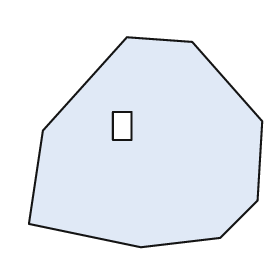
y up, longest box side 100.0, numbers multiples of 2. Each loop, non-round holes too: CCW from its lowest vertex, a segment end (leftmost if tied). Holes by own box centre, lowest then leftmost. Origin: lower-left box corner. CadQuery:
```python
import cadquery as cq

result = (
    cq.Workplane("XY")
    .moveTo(48.0, 0.0)
    .lineTo(82.0, 4.0)
    .lineTo(98.0, 20.0)
    .lineTo(100.0, 54.0)
    .lineTo(70.0, 88.0)
    .lineTo(42.0, 90.0)
    .lineTo(6.0, 50.0)
    .lineTo(0.0, 10.0)
    .close()
    .moveTo(36.0, 46.0)
    .lineTo(44.0, 46.0)
    .lineTo(44.0, 58.0)
    .lineTo(36.0, 58.0)
    .close()
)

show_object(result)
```